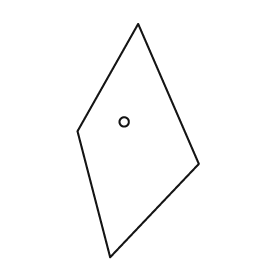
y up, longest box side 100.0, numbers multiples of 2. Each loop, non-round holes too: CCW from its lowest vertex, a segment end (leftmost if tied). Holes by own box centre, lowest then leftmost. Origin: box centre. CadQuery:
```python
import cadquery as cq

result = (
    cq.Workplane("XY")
    .moveTo(-12.0, -50.0)
    .lineTo(26.0, -10.0)
    .lineTo(0.0, 50.0)
    .lineTo(-26.0, 4.0)
    .close()
    .moveTo(-6.0, 8.0)
    .circle(2.0)
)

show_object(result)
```